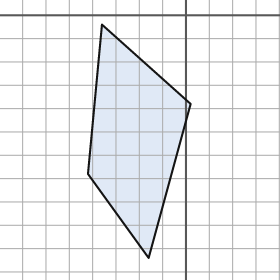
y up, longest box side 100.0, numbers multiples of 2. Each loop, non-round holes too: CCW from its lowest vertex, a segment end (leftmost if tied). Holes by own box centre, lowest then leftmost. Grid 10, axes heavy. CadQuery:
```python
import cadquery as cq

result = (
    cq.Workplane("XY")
    .moveTo(-16.0, -104.0)
    .lineTo(2.0, -38.0)
    .lineTo(-36.0, -4.0)
    .lineTo(-42.0, -68.0)
    .close()
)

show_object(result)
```